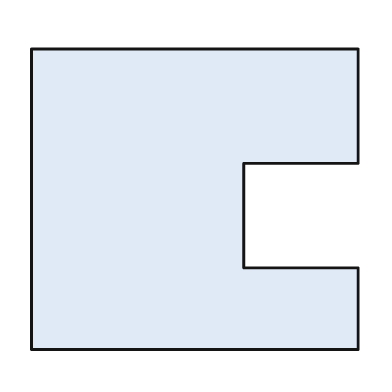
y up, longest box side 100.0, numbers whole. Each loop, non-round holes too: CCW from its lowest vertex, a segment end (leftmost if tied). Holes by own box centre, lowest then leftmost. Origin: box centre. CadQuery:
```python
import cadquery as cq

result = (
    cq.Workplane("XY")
    .moveTo(-50.0, -46.0)
    .lineTo(50.0, -46.0)
    .lineTo(50.0, -21.0)
    .lineTo(15.0, -21.0)
    .lineTo(15.0, 11.0)
    .lineTo(50.0, 11.0)
    .lineTo(50.0, 46.0)
    .lineTo(-50.0, 46.0)
    .close()
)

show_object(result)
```